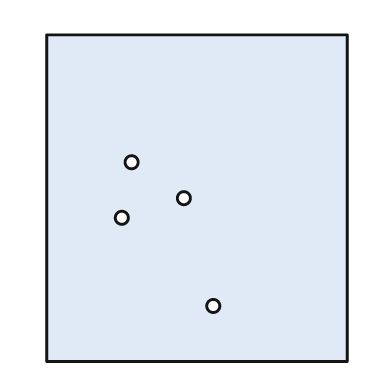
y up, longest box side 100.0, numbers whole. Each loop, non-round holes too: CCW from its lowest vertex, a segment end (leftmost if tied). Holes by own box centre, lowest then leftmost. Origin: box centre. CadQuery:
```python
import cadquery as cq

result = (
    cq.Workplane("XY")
    .moveTo(-46.0, -50.0)
    .lineTo(46.0, -50.0)
    .lineTo(46.0, 50.0)
    .lineTo(-46.0, 50.0)
    .close()
    .moveTo(5.0, -33.0)
    .circle(2.0)
    .moveTo(-23.0, -6.0)
    .circle(2.0)
    .moveTo(-4.0, 0.0)
    .circle(2.0)
    .moveTo(-20.0, 11.0)
    .circle(2.0)
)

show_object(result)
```